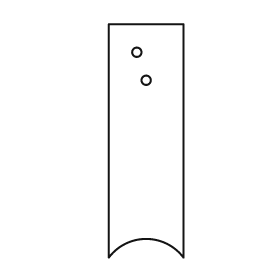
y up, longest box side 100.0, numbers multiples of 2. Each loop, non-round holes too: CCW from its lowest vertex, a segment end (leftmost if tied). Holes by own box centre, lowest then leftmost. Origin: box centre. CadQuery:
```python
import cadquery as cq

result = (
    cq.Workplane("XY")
    .moveTo(-16.0, -50.0)
    .threePointArc((0.0, -42.0), (16.0, -50.0))
    .lineTo(16.0, 50.0)
    .lineTo(-16.0, 50.0)
    .close()
    .moveTo(0.0, 26.0)
    .circle(2.0)
    .moveTo(-4.0, 38.0)
    .circle(2.0)
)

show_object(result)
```